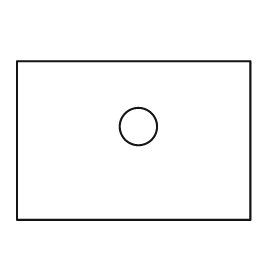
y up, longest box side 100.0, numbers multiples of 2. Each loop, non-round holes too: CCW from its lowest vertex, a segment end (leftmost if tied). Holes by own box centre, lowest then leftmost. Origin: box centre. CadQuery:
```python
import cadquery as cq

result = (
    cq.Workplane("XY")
    .moveTo(-50.0, -34.0)
    .lineTo(50.0, -34.0)
    .lineTo(50.0, 34.0)
    .lineTo(-50.0, 34.0)
    .close()
    .moveTo(2.0, 6.0)
    .circle(8.0)
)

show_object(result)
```